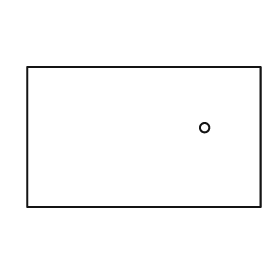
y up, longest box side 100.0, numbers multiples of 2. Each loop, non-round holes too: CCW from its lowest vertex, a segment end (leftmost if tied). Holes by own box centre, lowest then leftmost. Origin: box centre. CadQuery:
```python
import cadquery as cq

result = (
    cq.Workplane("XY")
    .moveTo(-50.0, -30.0)
    .lineTo(50.0, -30.0)
    .lineTo(50.0, 30.0)
    .lineTo(-50.0, 30.0)
    .close()
    .moveTo(26.0, 4.0)
    .circle(2.0)
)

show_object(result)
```